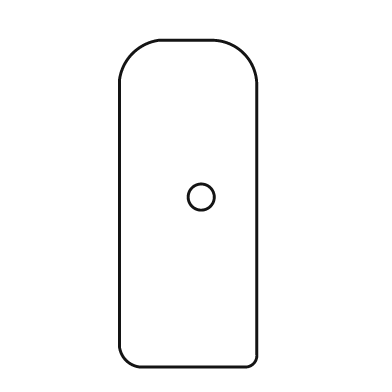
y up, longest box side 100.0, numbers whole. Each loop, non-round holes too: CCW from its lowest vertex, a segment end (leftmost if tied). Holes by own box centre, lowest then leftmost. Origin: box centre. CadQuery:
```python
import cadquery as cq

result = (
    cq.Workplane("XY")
    .moveTo(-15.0, -50.0)
    .lineTo(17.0, -50.0)
    .threePointArc((20.0, -49.0), (21.0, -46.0))
    .lineTo(21.0, 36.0)
    .threePointArc((17.0, 46.0), (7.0, 50.0))
    .lineTo(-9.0, 50.0)
    .threePointArc((-17.0, 46.0), (-21.0, 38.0))
    .lineTo(-21.0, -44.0)
    .threePointArc((-19.0, -48.0), (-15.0, -50.0))
    .close()
    .moveTo(4.0, 2.0)
    .circle(4.0)
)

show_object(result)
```